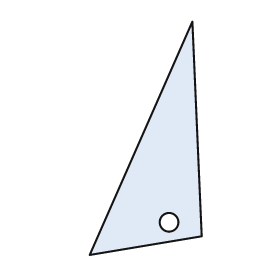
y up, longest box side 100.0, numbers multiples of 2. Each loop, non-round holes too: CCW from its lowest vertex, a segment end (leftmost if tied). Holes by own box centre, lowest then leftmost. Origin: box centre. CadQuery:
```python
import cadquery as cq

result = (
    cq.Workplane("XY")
    .moveTo(-24.0, -50.0)
    .lineTo(24.0, -42.0)
    .lineTo(20.0, 50.0)
    .close()
    .moveTo(10.0, -36.0)
    .circle(4.0)
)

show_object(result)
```